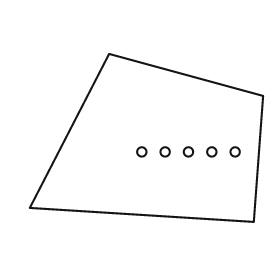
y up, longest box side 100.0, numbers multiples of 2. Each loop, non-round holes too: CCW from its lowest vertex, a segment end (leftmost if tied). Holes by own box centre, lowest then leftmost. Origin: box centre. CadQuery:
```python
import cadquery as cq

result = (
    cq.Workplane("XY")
    .moveTo(46.0, -36.0)
    .lineTo(50.0, 18.0)
    .lineTo(-16.0, 36.0)
    .lineTo(-50.0, -30.0)
    .close()
    .moveTo(-2.0, -6.0)
    .circle(2.0)
    .moveTo(8.0, -6.0)
    .circle(2.0)
    .moveTo(18.0, -6.0)
    .circle(2.0)
    .moveTo(28.0, -6.0)
    .circle(2.0)
    .moveTo(38.0, -6.0)
    .circle(2.0)
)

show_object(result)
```